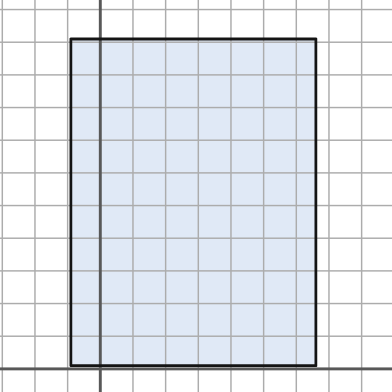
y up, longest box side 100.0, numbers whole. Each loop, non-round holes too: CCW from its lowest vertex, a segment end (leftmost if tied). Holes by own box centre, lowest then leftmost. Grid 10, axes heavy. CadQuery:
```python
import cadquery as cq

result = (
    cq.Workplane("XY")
    .moveTo(-9.0, 1.0)
    .lineTo(66.0, 1.0)
    .lineTo(66.0, 101.0)
    .lineTo(-9.0, 101.0)
    .close()
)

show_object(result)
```